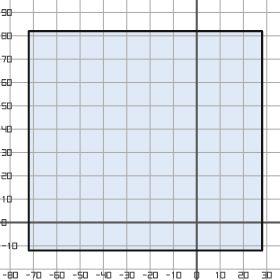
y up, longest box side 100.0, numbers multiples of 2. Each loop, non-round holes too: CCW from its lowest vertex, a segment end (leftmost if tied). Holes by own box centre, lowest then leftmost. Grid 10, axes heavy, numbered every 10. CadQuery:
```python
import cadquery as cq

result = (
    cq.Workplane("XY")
    .moveTo(-72.0, -12.0)
    .lineTo(28.0, -12.0)
    .lineTo(28.0, 82.0)
    .lineTo(-72.0, 82.0)
    .close()
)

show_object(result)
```